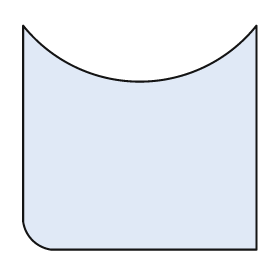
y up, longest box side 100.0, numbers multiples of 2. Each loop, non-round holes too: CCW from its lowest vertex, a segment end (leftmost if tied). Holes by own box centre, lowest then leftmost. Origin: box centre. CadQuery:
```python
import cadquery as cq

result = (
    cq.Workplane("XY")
    .moveTo(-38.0, -48.0)
    .lineTo(50.0, -48.0)
    .lineTo(50.0, 48.0)
    .threePointArc((0.0, 24.0), (-50.0, 48.0))
    .lineTo(-50.0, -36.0)
    .threePointArc((-46.0, -44.0), (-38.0, -48.0))
    .close()
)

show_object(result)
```